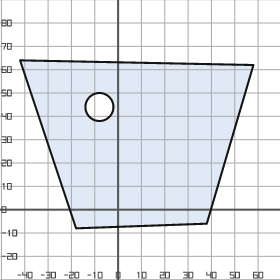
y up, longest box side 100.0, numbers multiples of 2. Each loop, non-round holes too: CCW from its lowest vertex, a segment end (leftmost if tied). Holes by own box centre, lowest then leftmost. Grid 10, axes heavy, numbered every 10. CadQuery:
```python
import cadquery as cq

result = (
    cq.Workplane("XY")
    .moveTo(-18.0, -8.0)
    .lineTo(38.0, -6.0)
    .lineTo(58.0, 62.0)
    .lineTo(-42.0, 64.0)
    .close()
    .moveTo(-8.0, 44.0)
    .circle(6.0)
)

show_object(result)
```